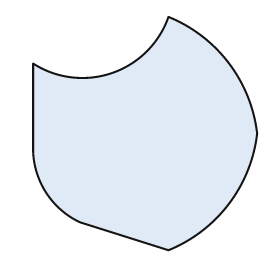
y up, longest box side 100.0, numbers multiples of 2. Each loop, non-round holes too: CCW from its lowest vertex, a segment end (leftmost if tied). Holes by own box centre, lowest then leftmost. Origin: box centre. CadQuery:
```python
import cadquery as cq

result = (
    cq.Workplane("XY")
    .moveTo(10.0, -50.0)
    .threePointArc((36.0, -30.0), (48.0, 0.0))
    .threePointArc((36.0, 30.0), (10.0, 50.0))
    .threePointArc((-14.0, 26.0), (-48.0, 30.0))
    .lineTo(-48.0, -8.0)
    .threePointArc((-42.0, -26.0), (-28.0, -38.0))
    .close()
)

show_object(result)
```